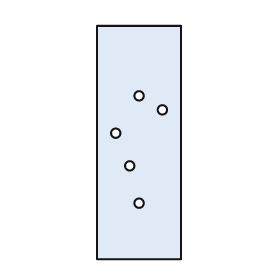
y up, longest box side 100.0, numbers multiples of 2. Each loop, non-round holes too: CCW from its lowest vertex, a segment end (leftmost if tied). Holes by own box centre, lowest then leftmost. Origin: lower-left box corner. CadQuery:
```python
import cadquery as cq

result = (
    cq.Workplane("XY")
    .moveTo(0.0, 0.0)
    .lineTo(36.0, 0.0)
    .lineTo(36.0, 100.0)
    .lineTo(0.0, 100.0)
    .close()
    .moveTo(18.0, 24.0)
    .circle(2.0)
    .moveTo(14.0, 40.0)
    .circle(2.0)
    .moveTo(8.0, 54.0)
    .circle(2.0)
    .moveTo(28.0, 64.0)
    .circle(2.0)
    .moveTo(18.0, 70.0)
    .circle(2.0)
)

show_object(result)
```